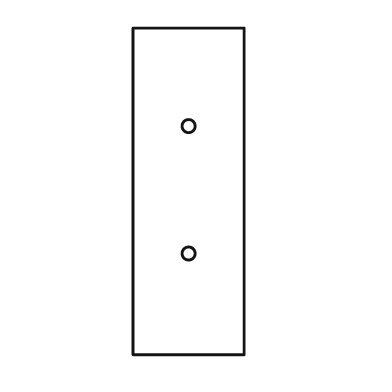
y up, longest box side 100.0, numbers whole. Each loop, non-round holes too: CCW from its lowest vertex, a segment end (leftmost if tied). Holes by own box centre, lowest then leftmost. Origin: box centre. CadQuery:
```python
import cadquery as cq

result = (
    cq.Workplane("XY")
    .moveTo(-17.0, -50.0)
    .lineTo(17.0, -50.0)
    .lineTo(17.0, 50.0)
    .lineTo(-17.0, 50.0)
    .close()
    .moveTo(0.0, -19.0)
    .circle(2.0)
    .moveTo(0.0, 20.0)
    .circle(2.0)
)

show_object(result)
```